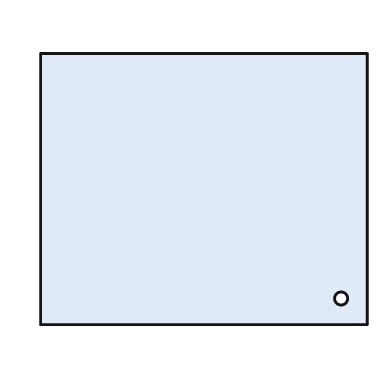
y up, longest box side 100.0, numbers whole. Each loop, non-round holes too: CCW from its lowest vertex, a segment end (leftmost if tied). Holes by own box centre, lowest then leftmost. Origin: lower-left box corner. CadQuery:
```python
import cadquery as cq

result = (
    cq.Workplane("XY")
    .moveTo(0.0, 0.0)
    .lineTo(100.0, 0.0)
    .lineTo(100.0, 83.0)
    .lineTo(0.0, 83.0)
    .close()
    .moveTo(92.0, 8.0)
    .circle(2.0)
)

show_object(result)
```